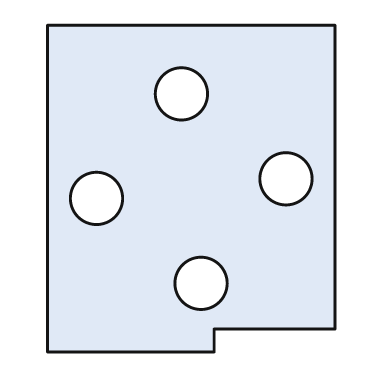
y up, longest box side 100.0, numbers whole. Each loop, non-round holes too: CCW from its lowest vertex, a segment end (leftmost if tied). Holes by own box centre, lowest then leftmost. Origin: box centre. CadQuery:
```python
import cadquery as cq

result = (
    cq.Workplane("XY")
    .moveTo(-44.0, -50.0)
    .lineTo(7.0, -50.0)
    .lineTo(7.0, -43.0)
    .lineTo(44.0, -43.0)
    .lineTo(44.0, 50.0)
    .lineTo(-44.0, 50.0)
    .close()
    .moveTo(3.0, -29.0)
    .circle(8.0)
    .moveTo(-29.0, -3.0)
    .circle(8.0)
    .moveTo(29.0, 3.0)
    .circle(8.0)
    .moveTo(-3.0, 29.0)
    .circle(8.0)
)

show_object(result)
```